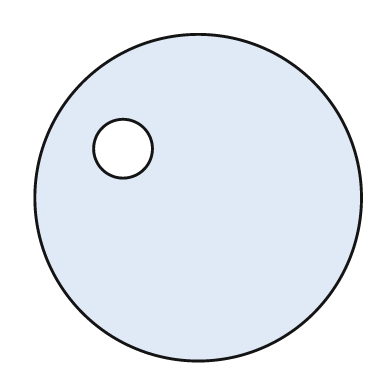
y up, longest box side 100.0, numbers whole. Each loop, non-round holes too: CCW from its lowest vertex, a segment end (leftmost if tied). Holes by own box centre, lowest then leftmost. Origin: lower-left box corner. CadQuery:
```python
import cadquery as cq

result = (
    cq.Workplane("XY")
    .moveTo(50.0, 50.0)
    .circle(50.0)
    .moveTo(27.0, 65.0)
    .circle(9.0)
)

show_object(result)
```